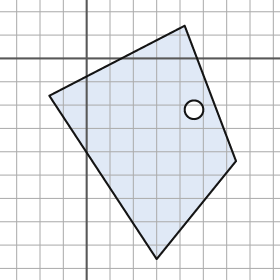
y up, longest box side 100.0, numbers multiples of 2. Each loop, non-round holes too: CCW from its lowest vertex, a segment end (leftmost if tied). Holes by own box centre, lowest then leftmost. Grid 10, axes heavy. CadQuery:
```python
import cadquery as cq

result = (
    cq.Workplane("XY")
    .moveTo(30.0, -86.0)
    .lineTo(64.0, -44.0)
    .lineTo(42.0, 14.0)
    .lineTo(-16.0, -16.0)
    .close()
    .moveTo(46.0, -22.0)
    .circle(4.0)
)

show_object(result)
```